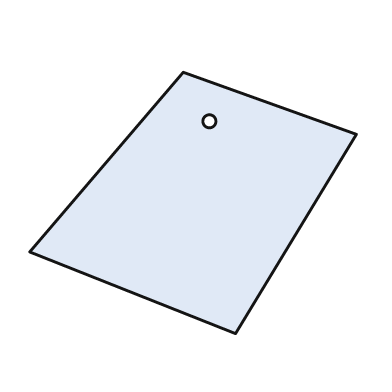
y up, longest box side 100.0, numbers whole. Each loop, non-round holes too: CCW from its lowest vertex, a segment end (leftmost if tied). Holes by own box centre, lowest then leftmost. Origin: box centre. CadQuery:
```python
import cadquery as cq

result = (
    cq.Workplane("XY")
    .moveTo(13.0, -40.0)
    .lineTo(50.0, 21.0)
    .lineTo(-3.0, 40.0)
    .lineTo(-50.0, -15.0)
    .close()
    .moveTo(5.0, 25.0)
    .circle(2.0)
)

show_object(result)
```